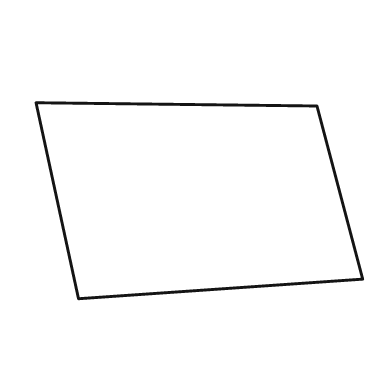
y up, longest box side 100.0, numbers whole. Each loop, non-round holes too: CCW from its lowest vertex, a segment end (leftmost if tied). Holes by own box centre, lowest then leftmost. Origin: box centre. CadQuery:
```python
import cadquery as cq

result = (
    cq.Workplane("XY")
    .moveTo(-37.0, -30.0)
    .lineTo(50.0, -24.0)
    .lineTo(36.0, 29.0)
    .lineTo(-50.0, 30.0)
    .close()
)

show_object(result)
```